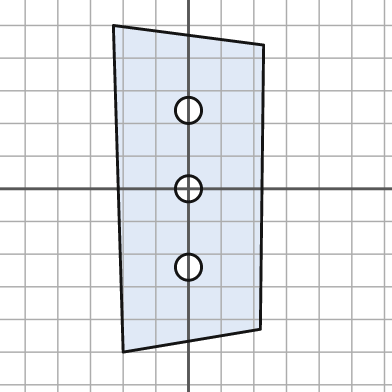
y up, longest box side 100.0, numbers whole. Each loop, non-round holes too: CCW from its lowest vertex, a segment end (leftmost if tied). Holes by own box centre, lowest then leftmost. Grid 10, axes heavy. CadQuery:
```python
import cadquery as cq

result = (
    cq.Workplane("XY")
    .moveTo(-20.0, -50.0)
    .lineTo(22.0, -43.0)
    .lineTo(23.0, 44.0)
    .lineTo(-23.0, 50.0)
    .close()
    .moveTo(0.0, -24.0)
    .circle(4.0)
    .moveTo(0.0, 0.0)
    .circle(4.0)
    .moveTo(0.0, 24.0)
    .circle(4.0)
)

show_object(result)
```